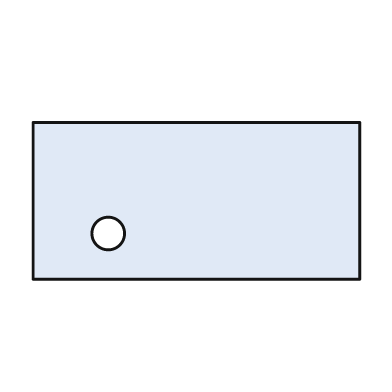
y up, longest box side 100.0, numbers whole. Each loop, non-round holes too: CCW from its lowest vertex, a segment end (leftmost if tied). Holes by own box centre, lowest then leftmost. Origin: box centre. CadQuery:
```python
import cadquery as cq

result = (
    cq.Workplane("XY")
    .moveTo(-50.0, -24.0)
    .lineTo(50.0, -24.0)
    .lineTo(50.0, 24.0)
    .lineTo(-50.0, 24.0)
    .close()
    .moveTo(-27.0, -10.0)
    .circle(5.0)
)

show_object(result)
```